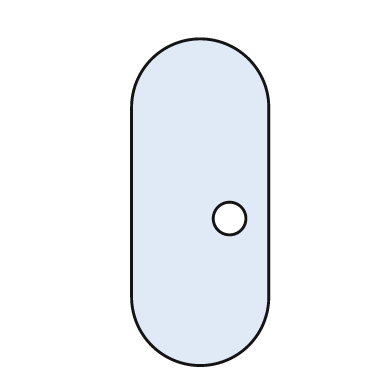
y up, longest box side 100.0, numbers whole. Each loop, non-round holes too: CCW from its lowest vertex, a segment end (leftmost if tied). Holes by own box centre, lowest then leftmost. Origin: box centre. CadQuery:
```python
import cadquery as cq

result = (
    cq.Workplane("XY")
    .moveTo(-21.0, -29.0)
    .threePointArc((0.0, -50.0), (21.0, -29.0))
    .lineTo(21.0, 29.0)
    .threePointArc((0.0, 50.0), (-21.0, 29.0))
    .close()
    .moveTo(9.0, -5.0)
    .circle(5.0)
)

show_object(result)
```